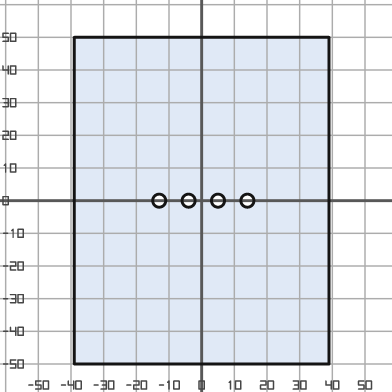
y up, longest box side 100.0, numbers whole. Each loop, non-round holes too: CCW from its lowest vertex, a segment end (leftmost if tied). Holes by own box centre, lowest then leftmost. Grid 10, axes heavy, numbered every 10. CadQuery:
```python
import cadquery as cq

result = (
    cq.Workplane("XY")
    .moveTo(-39.0, -50.0)
    .lineTo(39.0, -50.0)
    .lineTo(39.0, 50.0)
    .lineTo(-39.0, 50.0)
    .close()
    .moveTo(-13.0, 0.0)
    .circle(2.0)
    .moveTo(-4.0, 0.0)
    .circle(2.0)
    .moveTo(5.0, 0.0)
    .circle(2.0)
    .moveTo(14.0, 0.0)
    .circle(2.0)
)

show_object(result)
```